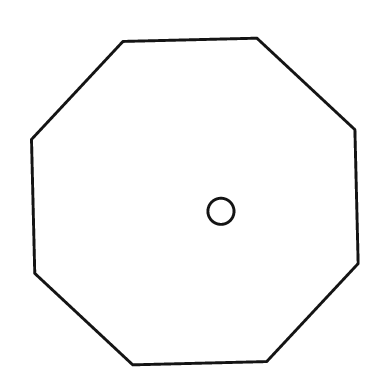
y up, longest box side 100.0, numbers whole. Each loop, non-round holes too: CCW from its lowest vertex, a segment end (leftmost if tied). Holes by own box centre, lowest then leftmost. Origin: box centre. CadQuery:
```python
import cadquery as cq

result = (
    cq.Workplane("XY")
    .moveTo(-19.0, -50.0)
    .lineTo(22.0, -49.0)
    .lineTo(50.0, -19.0)
    .lineTo(49.0, 22.0)
    .lineTo(19.0, 50.0)
    .lineTo(-22.0, 49.0)
    .lineTo(-50.0, 19.0)
    .lineTo(-49.0, -22.0)
    .close()
    .moveTo(8.0, -3.0)
    .circle(4.0)
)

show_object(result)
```